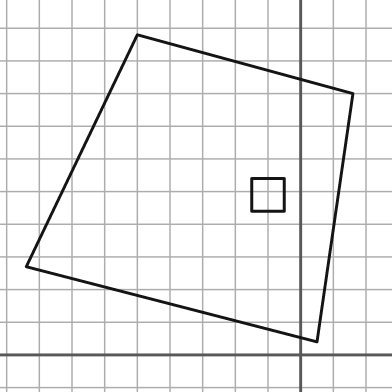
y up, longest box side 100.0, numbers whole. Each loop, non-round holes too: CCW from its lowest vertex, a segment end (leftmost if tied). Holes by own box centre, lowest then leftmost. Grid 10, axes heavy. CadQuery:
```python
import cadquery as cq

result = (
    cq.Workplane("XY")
    .moveTo(5.0, 4.0)
    .lineTo(16.0, 80.0)
    .lineTo(-50.0, 98.0)
    .lineTo(-84.0, 27.0)
    .close()
    .moveTo(-15.0, 44.0)
    .lineTo(-5.0, 44.0)
    .lineTo(-5.0, 54.0)
    .lineTo(-15.0, 54.0)
    .close()
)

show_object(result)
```